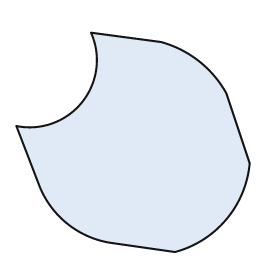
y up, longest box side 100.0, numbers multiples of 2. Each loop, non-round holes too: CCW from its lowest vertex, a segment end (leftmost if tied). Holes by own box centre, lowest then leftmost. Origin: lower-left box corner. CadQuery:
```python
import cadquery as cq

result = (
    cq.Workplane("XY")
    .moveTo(68.0, 0.0)
    .threePointArc((90.0, 14.0), (100.0, 38.0))
    .lineTo(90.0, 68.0)
    .threePointArc((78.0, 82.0), (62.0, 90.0))
    .lineTo(32.0, 94.0)
    .threePointArc((28.0, 64.0), (0.0, 54.0))
    .lineTo(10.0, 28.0)
    .threePointArc((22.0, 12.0), (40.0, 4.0))
    .close()
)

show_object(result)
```